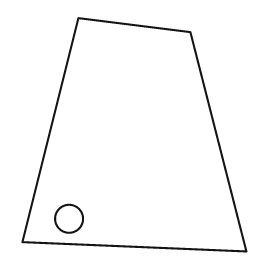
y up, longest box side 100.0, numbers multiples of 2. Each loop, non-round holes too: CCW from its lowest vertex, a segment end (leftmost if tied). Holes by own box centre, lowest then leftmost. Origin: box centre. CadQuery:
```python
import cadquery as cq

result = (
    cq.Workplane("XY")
    .moveTo(48.0, -50.0)
    .lineTo(24.0, 44.0)
    .lineTo(-24.0, 50.0)
    .lineTo(-48.0, -46.0)
    .close()
    .moveTo(-28.0, -36.0)
    .circle(6.0)
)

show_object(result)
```